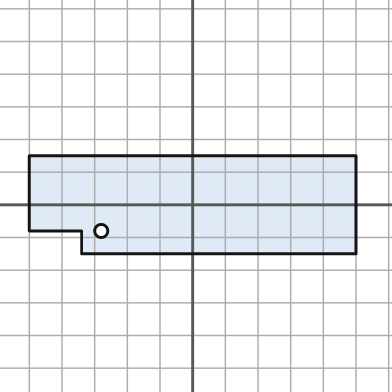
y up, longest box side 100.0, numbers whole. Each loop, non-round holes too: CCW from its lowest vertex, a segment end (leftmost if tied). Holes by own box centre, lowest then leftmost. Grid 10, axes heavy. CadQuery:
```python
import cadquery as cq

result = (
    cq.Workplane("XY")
    .moveTo(-34.0, -15.0)
    .lineTo(50.0, -15.0)
    .lineTo(50.0, 15.0)
    .lineTo(-50.0, 15.0)
    .lineTo(-50.0, -8.0)
    .lineTo(-34.0, -8.0)
    .close()
    .moveTo(-28.0, -8.0)
    .circle(2.0)
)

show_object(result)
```